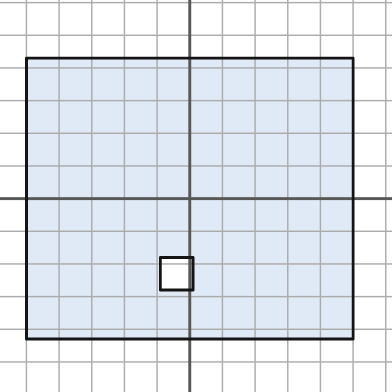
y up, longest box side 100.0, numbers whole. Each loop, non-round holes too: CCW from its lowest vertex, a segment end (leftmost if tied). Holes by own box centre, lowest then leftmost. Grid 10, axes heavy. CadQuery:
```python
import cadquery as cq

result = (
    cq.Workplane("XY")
    .moveTo(-50.0, -43.0)
    .lineTo(50.0, -43.0)
    .lineTo(50.0, 43.0)
    .lineTo(-50.0, 43.0)
    .close()
    .moveTo(-9.0, -28.0)
    .lineTo(1.0, -28.0)
    .lineTo(1.0, -18.0)
    .lineTo(-9.0, -18.0)
    .close()
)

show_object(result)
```